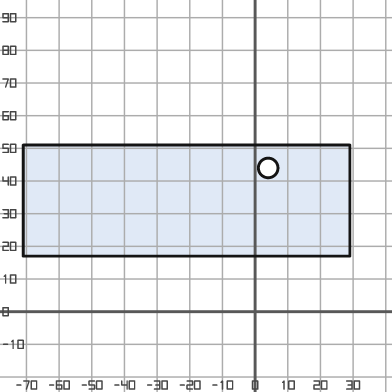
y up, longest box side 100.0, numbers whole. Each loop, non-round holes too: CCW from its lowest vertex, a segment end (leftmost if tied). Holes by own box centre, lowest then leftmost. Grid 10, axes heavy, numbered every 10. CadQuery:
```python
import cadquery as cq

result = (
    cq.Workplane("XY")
    .moveTo(-71.0, 17.0)
    .lineTo(29.0, 17.0)
    .lineTo(29.0, 51.0)
    .lineTo(-71.0, 51.0)
    .close()
    .moveTo(4.0, 44.0)
    .circle(3.0)
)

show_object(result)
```